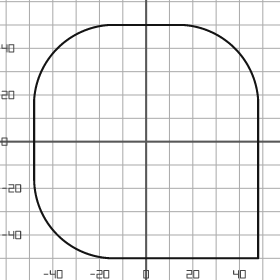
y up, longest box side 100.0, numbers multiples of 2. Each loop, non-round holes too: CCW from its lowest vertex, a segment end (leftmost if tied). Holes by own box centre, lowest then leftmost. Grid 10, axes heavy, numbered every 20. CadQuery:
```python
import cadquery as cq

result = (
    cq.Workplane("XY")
    .moveTo(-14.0, -50.0)
    .lineTo(48.0, -50.0)
    .lineTo(48.0, 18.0)
    .threePointArc((38.0, 40.0), (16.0, 50.0))
    .lineTo(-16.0, 50.0)
    .threePointArc((-38.0, 40.0), (-48.0, 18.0))
    .lineTo(-48.0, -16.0)
    .threePointArc((-38.0, -40.0), (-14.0, -50.0))
    .close()
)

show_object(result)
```